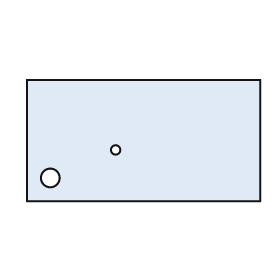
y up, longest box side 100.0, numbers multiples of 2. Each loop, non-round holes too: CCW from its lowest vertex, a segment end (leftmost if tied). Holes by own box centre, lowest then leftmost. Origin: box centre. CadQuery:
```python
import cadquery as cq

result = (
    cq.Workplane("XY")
    .moveTo(-50.0, -26.0)
    .lineTo(50.0, -26.0)
    .lineTo(50.0, 26.0)
    .lineTo(-50.0, 26.0)
    .close()
    .moveTo(-40.0, -16.0)
    .circle(4.0)
    .moveTo(-12.0, -4.0)
    .circle(2.0)
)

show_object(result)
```